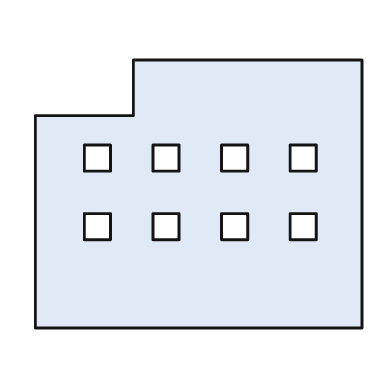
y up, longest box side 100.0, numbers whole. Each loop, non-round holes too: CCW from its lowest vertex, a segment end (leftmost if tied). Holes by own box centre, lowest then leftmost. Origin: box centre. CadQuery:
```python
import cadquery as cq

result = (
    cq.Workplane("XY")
    .moveTo(-50.0, -41.0)
    .lineTo(50.0, -41.0)
    .lineTo(50.0, 41.0)
    .lineTo(-20.0, 41.0)
    .lineTo(-20.0, 24.0)
    .lineTo(-50.0, 24.0)
    .close()
    .moveTo(-35.0, -14.0)
    .lineTo(-27.0, -14.0)
    .lineTo(-27.0, -6.0)
    .lineTo(-35.0, -6.0)
    .close()
    .moveTo(-14.0, -14.0)
    .lineTo(-6.0, -14.0)
    .lineTo(-6.0, -6.0)
    .lineTo(-14.0, -6.0)
    .close()
    .moveTo(7.0, -14.0)
    .lineTo(15.0, -14.0)
    .lineTo(15.0, -6.0)
    .lineTo(7.0, -6.0)
    .close()
    .moveTo(28.0, -14.0)
    .lineTo(36.0, -14.0)
    .lineTo(36.0, -6.0)
    .lineTo(28.0, -6.0)
    .close()
    .moveTo(-35.0, 7.0)
    .lineTo(-27.0, 7.0)
    .lineTo(-27.0, 15.0)
    .lineTo(-35.0, 15.0)
    .close()
    .moveTo(-14.0, 7.0)
    .lineTo(-6.0, 7.0)
    .lineTo(-6.0, 15.0)
    .lineTo(-14.0, 15.0)
    .close()
    .moveTo(7.0, 7.0)
    .lineTo(15.0, 7.0)
    .lineTo(15.0, 15.0)
    .lineTo(7.0, 15.0)
    .close()
    .moveTo(28.0, 7.0)
    .lineTo(36.0, 7.0)
    .lineTo(36.0, 15.0)
    .lineTo(28.0, 15.0)
    .close()
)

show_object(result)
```